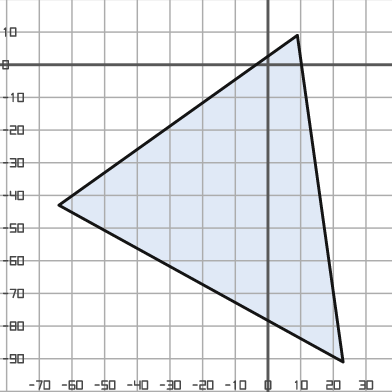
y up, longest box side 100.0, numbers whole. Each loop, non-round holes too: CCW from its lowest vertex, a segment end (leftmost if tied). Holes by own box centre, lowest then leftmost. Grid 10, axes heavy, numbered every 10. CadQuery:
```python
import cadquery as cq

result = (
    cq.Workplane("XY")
    .moveTo(23.0, -91.0)
    .lineTo(9.0, 9.0)
    .lineTo(-64.0, -43.0)
    .close()
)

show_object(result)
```